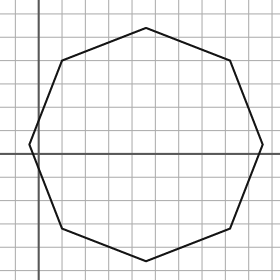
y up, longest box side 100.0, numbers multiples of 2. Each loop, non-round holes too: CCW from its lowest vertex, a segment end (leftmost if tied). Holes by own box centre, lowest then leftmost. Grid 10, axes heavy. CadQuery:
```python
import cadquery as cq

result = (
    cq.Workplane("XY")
    .moveTo(46.0, -46.0)
    .lineTo(82.0, -32.0)
    .lineTo(96.0, 4.0)
    .lineTo(82.0, 40.0)
    .lineTo(46.0, 54.0)
    .lineTo(10.0, 40.0)
    .lineTo(-4.0, 4.0)
    .lineTo(10.0, -32.0)
    .close()
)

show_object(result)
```